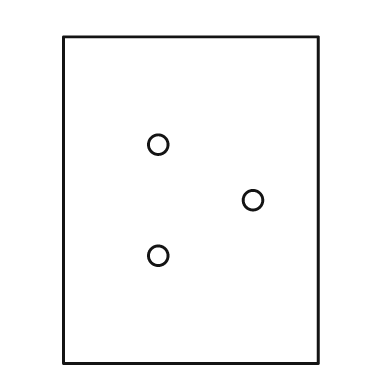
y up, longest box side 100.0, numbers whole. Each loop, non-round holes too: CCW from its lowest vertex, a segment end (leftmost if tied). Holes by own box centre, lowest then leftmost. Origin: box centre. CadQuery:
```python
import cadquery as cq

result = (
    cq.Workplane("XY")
    .moveTo(-39.0, -50.0)
    .lineTo(39.0, -50.0)
    .lineTo(39.0, 50.0)
    .lineTo(-39.0, 50.0)
    .close()
    .moveTo(-10.0, -17.0)
    .circle(3.0)
    .moveTo(19.0, 0.0)
    .circle(3.0)
    .moveTo(-10.0, 17.0)
    .circle(3.0)
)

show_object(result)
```